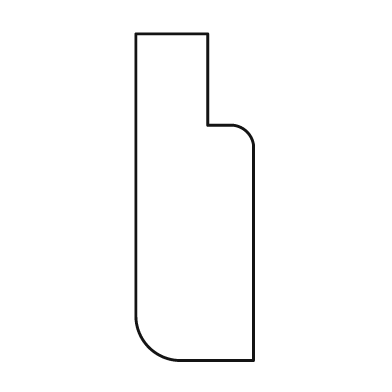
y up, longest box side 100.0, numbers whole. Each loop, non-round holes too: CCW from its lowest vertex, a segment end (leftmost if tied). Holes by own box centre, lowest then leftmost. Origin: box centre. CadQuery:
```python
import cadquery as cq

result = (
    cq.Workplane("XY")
    .moveTo(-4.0, -50.0)
    .lineTo(18.0, -50.0)
    .lineTo(18.0, 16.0)
    .threePointArc((16.0, 20.0), (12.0, 22.0))
    .lineTo(4.0, 22.0)
    .lineTo(4.0, 50.0)
    .lineTo(-18.0, 50.0)
    .lineTo(-18.0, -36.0)
    .threePointArc((-14.0, -46.0), (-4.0, -50.0))
    .close()
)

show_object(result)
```